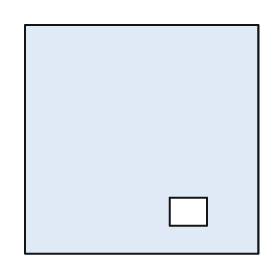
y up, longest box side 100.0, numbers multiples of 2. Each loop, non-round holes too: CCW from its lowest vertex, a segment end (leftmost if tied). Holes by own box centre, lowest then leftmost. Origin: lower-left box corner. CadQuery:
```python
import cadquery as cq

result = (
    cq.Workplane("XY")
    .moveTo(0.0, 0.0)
    .lineTo(100.0, 0.0)
    .lineTo(100.0, 98.0)
    .lineTo(0.0, 98.0)
    .close()
    .moveTo(62.0, 12.0)
    .lineTo(78.0, 12.0)
    .lineTo(78.0, 24.0)
    .lineTo(62.0, 24.0)
    .close()
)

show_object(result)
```